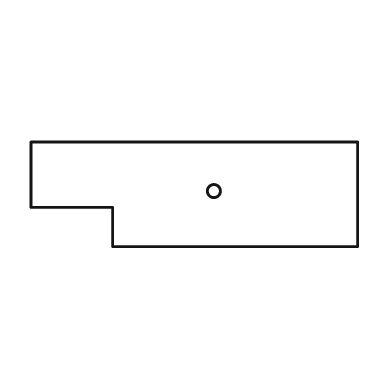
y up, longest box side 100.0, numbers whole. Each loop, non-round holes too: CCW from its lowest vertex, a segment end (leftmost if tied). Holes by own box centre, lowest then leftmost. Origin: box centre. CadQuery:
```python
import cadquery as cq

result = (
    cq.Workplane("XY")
    .moveTo(-25.0, -16.0)
    .lineTo(50.0, -16.0)
    .lineTo(50.0, 16.0)
    .lineTo(-50.0, 16.0)
    .lineTo(-50.0, -4.0)
    .lineTo(-25.0, -4.0)
    .close()
    .moveTo(6.0, 1.0)
    .circle(2.0)
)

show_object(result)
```